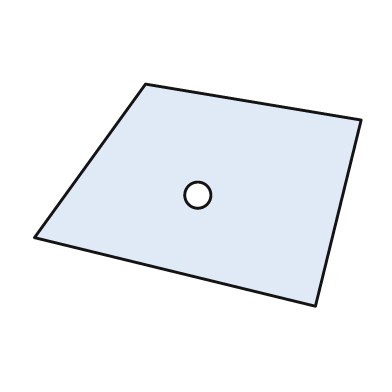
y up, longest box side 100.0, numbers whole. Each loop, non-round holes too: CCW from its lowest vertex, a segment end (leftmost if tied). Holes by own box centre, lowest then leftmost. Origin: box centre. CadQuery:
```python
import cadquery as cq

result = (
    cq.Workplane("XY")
    .moveTo(36.0, -34.0)
    .lineTo(50.0, 23.0)
    .lineTo(-16.0, 34.0)
    .lineTo(-50.0, -13.0)
    .close()
    .moveTo(0.0, 0.0)
    .circle(4.0)
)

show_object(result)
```